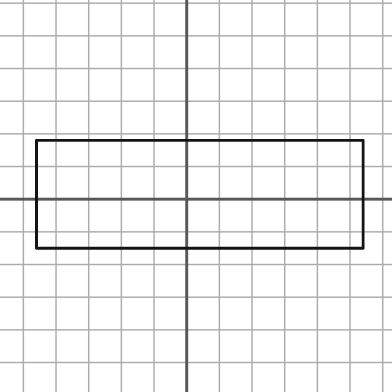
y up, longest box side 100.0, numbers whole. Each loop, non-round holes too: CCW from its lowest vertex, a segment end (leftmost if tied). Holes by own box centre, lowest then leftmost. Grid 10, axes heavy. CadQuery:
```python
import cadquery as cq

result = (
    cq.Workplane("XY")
    .moveTo(-46.0, -15.0)
    .lineTo(54.0, -15.0)
    .lineTo(54.0, 18.0)
    .lineTo(-46.0, 18.0)
    .close()
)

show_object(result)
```